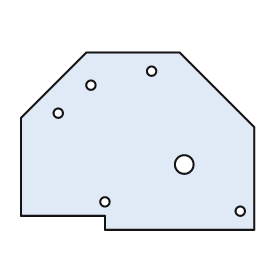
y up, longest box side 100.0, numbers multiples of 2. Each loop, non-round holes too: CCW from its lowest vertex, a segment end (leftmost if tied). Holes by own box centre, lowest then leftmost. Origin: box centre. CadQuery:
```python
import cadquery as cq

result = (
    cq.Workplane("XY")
    .moveTo(-14.0, -38.0)
    .lineTo(50.0, -38.0)
    .lineTo(50.0, 6.0)
    .lineTo(18.0, 38.0)
    .lineTo(-22.0, 38.0)
    .lineTo(-50.0, 10.0)
    .lineTo(-50.0, -32.0)
    .lineTo(-14.0, -32.0)
    .close()
    .moveTo(44.0, -30.0)
    .circle(2.0)
    .moveTo(-14.0, -26.0)
    .circle(2.0)
    .moveTo(20.0, -10.0)
    .circle(4.0)
    .moveTo(-34.0, 12.0)
    .circle(2.0)
    .moveTo(-20.0, 24.0)
    .circle(2.0)
    .moveTo(6.0, 30.0)
    .circle(2.0)
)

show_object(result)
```